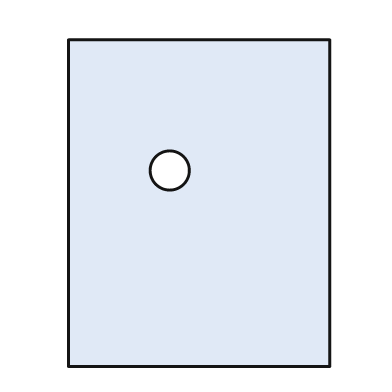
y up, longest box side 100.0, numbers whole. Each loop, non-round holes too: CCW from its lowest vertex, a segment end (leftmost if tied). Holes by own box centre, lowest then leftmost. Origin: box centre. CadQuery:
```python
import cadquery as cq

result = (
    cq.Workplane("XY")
    .moveTo(-40.0, -50.0)
    .lineTo(40.0, -50.0)
    .lineTo(40.0, 50.0)
    .lineTo(-40.0, 50.0)
    .close()
    .moveTo(-9.0, 10.0)
    .circle(6.0)
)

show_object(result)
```